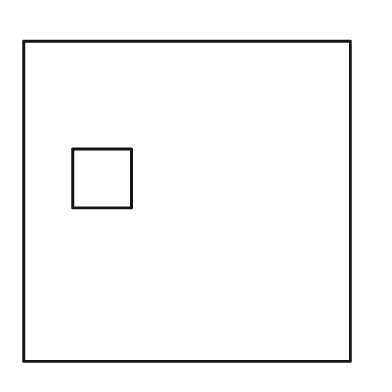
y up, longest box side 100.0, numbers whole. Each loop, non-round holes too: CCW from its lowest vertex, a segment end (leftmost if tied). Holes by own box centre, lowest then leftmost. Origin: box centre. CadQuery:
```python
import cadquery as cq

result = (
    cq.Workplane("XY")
    .moveTo(-50.0, -49.0)
    .lineTo(50.0, -49.0)
    .lineTo(50.0, 49.0)
    .lineTo(-50.0, 49.0)
    .close()
    .moveTo(-35.0, -2.0)
    .lineTo(-17.0, -2.0)
    .lineTo(-17.0, 16.0)
    .lineTo(-35.0, 16.0)
    .close()
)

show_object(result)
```